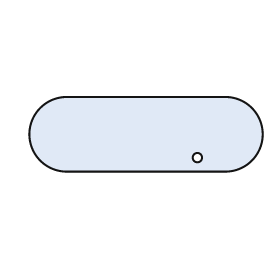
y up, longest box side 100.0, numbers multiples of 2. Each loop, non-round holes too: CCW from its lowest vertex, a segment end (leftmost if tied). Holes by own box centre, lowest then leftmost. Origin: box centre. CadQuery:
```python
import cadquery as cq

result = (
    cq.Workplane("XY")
    .moveTo(-34.0, -16.0)
    .lineTo(34.0, -16.0)
    .threePointArc((50.0, 0.0), (34.0, 16.0))
    .lineTo(-34.0, 16.0)
    .threePointArc((-50.0, 0.0), (-34.0, -16.0))
    .close()
    .moveTo(22.0, -10.0)
    .circle(2.0)
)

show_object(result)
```